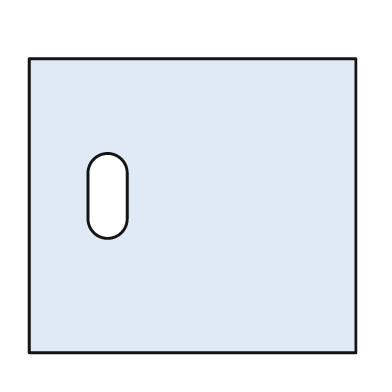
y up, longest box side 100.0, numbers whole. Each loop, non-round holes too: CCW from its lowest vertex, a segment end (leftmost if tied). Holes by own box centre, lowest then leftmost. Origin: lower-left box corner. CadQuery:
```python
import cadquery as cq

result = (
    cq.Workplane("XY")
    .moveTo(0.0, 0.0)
    .lineTo(100.0, 0.0)
    .lineTo(100.0, 90.0)
    .lineTo(0.0, 90.0)
    .close()
    .moveTo(18.0, 41.0)
    .threePointArc((24.0, 35.0), (30.0, 41.0))
    .lineTo(30.0, 55.0)
    .threePointArc((24.0, 61.0), (18.0, 55.0))
    .close()
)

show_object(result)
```